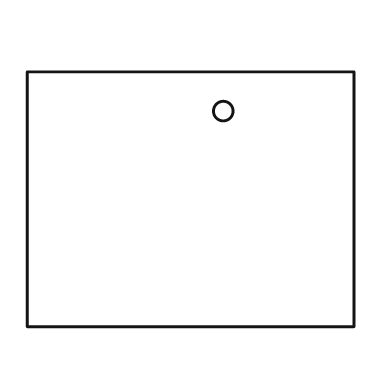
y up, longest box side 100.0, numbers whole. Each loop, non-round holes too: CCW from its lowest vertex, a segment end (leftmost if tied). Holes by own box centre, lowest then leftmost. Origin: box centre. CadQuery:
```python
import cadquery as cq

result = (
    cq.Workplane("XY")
    .moveTo(-50.0, -39.0)
    .lineTo(50.0, -39.0)
    .lineTo(50.0, 39.0)
    .lineTo(-50.0, 39.0)
    .close()
    .moveTo(10.0, 27.0)
    .circle(3.0)
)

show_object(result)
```